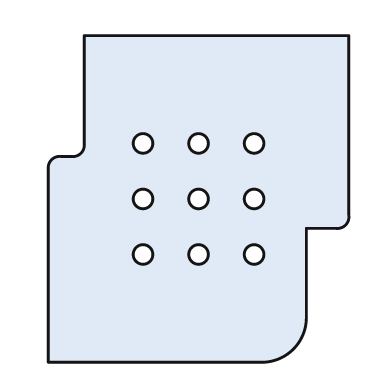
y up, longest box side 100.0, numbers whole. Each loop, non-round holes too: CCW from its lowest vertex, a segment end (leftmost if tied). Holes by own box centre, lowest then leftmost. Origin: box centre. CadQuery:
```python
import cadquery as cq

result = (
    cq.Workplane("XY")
    .moveTo(-46.0, -50.0)
    .lineTo(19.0, -50.0)
    .threePointArc((29.0, -46.0), (33.0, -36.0))
    .lineTo(33.0, -9.0)
    .lineTo(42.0, -9.0)
    .threePointArc((45.0, -8.0), (46.0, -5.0))
    .lineTo(46.0, 50.0)
    .lineTo(-35.0, 50.0)
    .lineTo(-35.0, 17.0)
    .threePointArc((-36.0, 14.0), (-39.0, 13.0))
    .lineTo(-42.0, 13.0)
    .threePointArc((-45.0, 12.0), (-46.0, 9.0))
    .close()
    .moveTo(-17.0, -17.0)
    .circle(3.0)
    .moveTo(0.0, -17.0)
    .circle(3.0)
    .moveTo(17.0, -17.0)
    .circle(3.0)
    .moveTo(-17.0, 0.0)
    .circle(3.0)
    .moveTo(0.0, 0.0)
    .circle(3.0)
    .moveTo(17.0, 0.0)
    .circle(3.0)
    .moveTo(-17.0, 17.0)
    .circle(3.0)
    .moveTo(0.0, 17.0)
    .circle(3.0)
    .moveTo(17.0, 17.0)
    .circle(3.0)
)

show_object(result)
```